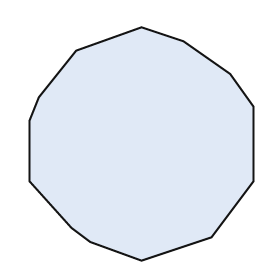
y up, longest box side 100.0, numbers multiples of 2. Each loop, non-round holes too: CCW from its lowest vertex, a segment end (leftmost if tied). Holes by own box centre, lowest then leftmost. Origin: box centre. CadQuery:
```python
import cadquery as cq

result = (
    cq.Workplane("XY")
    .moveTo(0.0, -50.0)
    .lineTo(30.0, -40.0)
    .lineTo(48.0, -16.0)
    .lineTo(48.0, 16.0)
    .lineTo(38.0, 30.0)
    .lineTo(18.0, 44.0)
    .lineTo(0.0, 50.0)
    .lineTo(-28.0, 40.0)
    .lineTo(-44.0, 20.0)
    .lineTo(-48.0, 10.0)
    .lineTo(-48.0, -16.0)
    .lineTo(-30.0, -36.0)
    .lineTo(-22.0, -42.0)
    .close()
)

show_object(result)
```